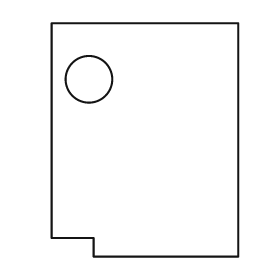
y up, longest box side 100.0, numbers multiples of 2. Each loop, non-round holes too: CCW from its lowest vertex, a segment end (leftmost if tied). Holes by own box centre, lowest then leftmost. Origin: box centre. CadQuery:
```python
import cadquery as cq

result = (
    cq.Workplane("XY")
    .moveTo(-22.0, -50.0)
    .lineTo(40.0, -50.0)
    .lineTo(40.0, 50.0)
    .lineTo(-40.0, 50.0)
    .lineTo(-40.0, -42.0)
    .lineTo(-22.0, -42.0)
    .close()
    .moveTo(-24.0, 26.0)
    .circle(10.0)
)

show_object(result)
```